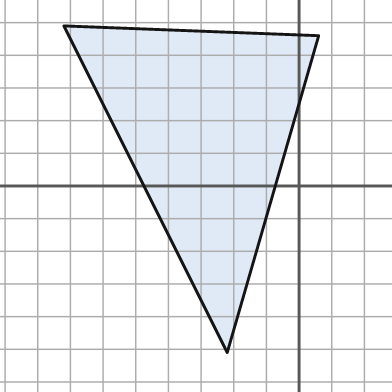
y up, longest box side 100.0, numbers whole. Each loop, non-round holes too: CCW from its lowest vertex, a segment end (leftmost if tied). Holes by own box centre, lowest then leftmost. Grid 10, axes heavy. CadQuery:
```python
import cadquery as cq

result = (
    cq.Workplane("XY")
    .moveTo(-22.0, -51.0)
    .lineTo(6.0, 46.0)
    .lineTo(-72.0, 49.0)
    .close()
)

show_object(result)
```